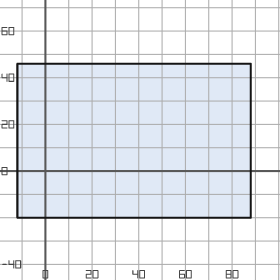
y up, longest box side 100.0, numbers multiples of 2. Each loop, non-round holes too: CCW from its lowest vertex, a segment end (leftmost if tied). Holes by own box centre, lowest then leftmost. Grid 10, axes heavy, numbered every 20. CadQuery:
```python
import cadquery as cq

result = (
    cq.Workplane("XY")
    .moveTo(-12.0, -20.0)
    .lineTo(88.0, -20.0)
    .lineTo(88.0, 46.0)
    .lineTo(-12.0, 46.0)
    .close()
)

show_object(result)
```